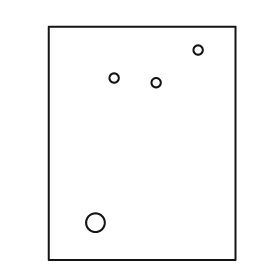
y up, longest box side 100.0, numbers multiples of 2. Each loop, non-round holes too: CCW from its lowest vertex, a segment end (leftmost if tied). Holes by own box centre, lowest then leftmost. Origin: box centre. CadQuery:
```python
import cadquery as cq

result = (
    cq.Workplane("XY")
    .moveTo(-40.0, -50.0)
    .lineTo(40.0, -50.0)
    .lineTo(40.0, 50.0)
    .lineTo(-40.0, 50.0)
    .close()
    .moveTo(-20.0, -34.0)
    .circle(4.0)
    .moveTo(6.0, 26.0)
    .circle(2.0)
    .moveTo(-12.0, 28.0)
    .circle(2.0)
    .moveTo(24.0, 40.0)
    .circle(2.0)
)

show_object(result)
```